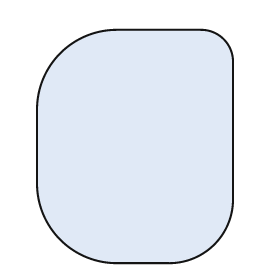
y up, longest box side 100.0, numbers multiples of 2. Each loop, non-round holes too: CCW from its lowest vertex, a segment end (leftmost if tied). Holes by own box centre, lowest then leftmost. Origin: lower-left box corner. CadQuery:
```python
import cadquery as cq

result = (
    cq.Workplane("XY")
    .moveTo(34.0, 0.0)
    .lineTo(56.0, 0.0)
    .threePointArc((76.0, 8.0), (84.0, 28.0))
    .lineTo(84.0, 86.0)
    .threePointArc((80.0, 96.0), (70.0, 100.0))
    .lineTo(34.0, 100.0)
    .threePointArc((10.0, 90.0), (0.0, 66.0))
    .lineTo(0.0, 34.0)
    .threePointArc((10.0, 10.0), (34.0, 0.0))
    .close()
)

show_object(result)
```